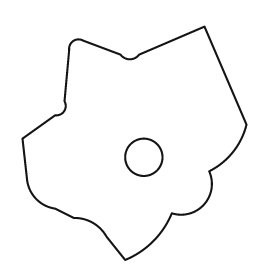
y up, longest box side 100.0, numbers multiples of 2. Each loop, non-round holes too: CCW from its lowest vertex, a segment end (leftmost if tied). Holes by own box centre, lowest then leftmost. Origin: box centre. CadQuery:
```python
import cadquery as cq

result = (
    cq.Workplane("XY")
    .moveTo(-4.0, -50.0)
    .threePointArc((8.0, -42.0), (16.0, -30.0))
    .threePointArc((30.0, -26.0), (32.0, -12.0))
    .threePointArc((42.0, -4.0), (48.0, 8.0))
    .lineTo(30.0, 50.0)
    .lineTo(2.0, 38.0)
    .threePointArc((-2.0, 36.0), (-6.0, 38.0))
    .lineTo(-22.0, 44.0)
    .threePointArc((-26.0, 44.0), (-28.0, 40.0))
    .lineTo(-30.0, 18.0)
    .threePointArc((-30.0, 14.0), (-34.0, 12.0))
    .lineTo(-48.0, 2.0)
    .lineTo(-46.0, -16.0)
    .threePointArc((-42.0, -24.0), (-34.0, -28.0))
    .lineTo(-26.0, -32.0)
    .threePointArc((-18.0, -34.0), (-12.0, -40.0))
    .close()
    .moveTo(4.0, -6.0)
    .circle(8.0)
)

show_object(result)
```